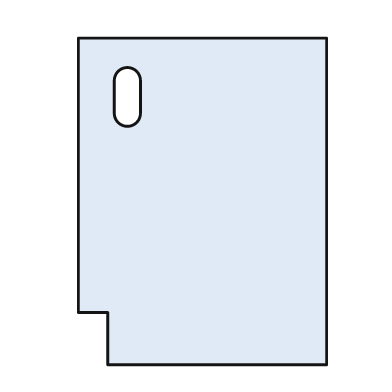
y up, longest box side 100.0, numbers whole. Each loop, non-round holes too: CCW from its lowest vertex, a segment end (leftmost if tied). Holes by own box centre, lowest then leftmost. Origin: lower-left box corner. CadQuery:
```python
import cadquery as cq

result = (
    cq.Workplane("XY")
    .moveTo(9.0, 0.0)
    .lineTo(76.0, 0.0)
    .lineTo(76.0, 100.0)
    .lineTo(0.0, 100.0)
    .lineTo(0.0, 16.0)
    .lineTo(9.0, 16.0)
    .close()
    .moveTo(11.0, 77.0)
    .threePointArc((15.0, 73.0), (19.0, 77.0))
    .lineTo(19.0, 87.0)
    .threePointArc((15.0, 91.0), (11.0, 87.0))
    .close()
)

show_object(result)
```